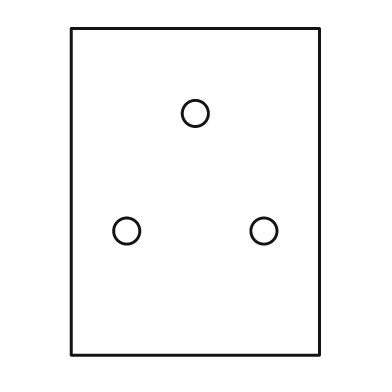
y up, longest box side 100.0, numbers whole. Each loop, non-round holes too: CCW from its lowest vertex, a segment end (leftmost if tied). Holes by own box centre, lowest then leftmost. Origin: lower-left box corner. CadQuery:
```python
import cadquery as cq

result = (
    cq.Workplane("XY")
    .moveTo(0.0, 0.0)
    .lineTo(76.0, 0.0)
    .lineTo(76.0, 100.0)
    .lineTo(0.0, 100.0)
    .close()
    .moveTo(17.0, 38.0)
    .circle(4.0)
    .moveTo(59.0, 38.0)
    .circle(4.0)
    .moveTo(38.0, 74.0)
    .circle(4.0)
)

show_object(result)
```